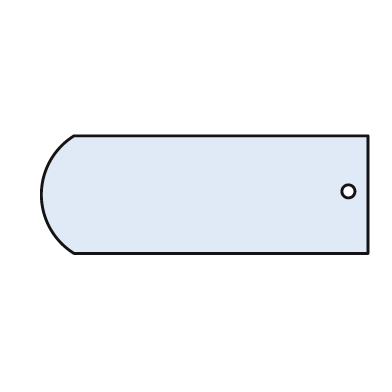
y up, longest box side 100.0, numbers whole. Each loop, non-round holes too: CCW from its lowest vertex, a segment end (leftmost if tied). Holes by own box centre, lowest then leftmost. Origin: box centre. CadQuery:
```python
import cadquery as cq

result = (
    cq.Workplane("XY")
    .moveTo(-40.0, -18.0)
    .lineTo(50.0, -18.0)
    .lineTo(50.0, 18.0)
    .lineTo(-40.0, 18.0)
    .threePointArc((-50.0, 0.0), (-40.0, -18.0))
    .close()
    .moveTo(44.0, 1.0)
    .circle(2.0)
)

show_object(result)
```